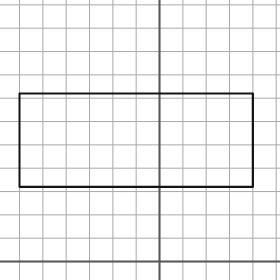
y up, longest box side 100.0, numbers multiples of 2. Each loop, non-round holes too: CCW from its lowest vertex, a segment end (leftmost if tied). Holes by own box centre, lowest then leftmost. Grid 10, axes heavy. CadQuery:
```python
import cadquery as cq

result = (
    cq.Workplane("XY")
    .moveTo(-60.0, 32.0)
    .lineTo(40.0, 32.0)
    .lineTo(40.0, 72.0)
    .lineTo(-60.0, 72.0)
    .close()
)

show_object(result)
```